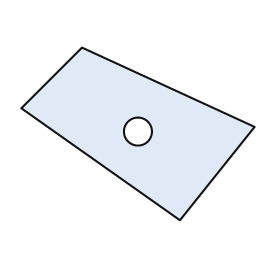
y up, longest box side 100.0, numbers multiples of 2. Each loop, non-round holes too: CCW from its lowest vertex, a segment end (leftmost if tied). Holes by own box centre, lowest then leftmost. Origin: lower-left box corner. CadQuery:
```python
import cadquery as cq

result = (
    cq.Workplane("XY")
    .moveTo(68.0, 0.0)
    .lineTo(100.0, 40.0)
    .lineTo(26.0, 74.0)
    .lineTo(0.0, 48.0)
    .close()
    .moveTo(50.0, 38.0)
    .circle(6.0)
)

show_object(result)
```